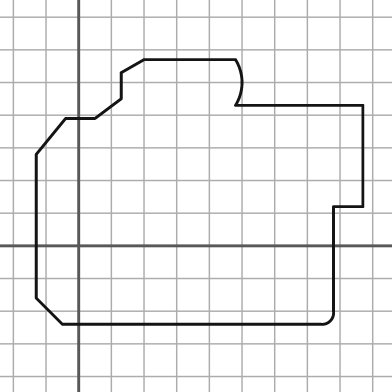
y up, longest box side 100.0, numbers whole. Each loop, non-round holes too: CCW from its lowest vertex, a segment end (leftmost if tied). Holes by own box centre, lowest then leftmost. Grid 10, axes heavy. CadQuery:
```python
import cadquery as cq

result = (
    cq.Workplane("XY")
    .moveTo(-5.0, -24.0)
    .lineTo(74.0, -24.0)
    .threePointArc((77.0, -23.0), (78.0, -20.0))
    .lineTo(78.0, 12.0)
    .lineTo(87.0, 12.0)
    .lineTo(87.0, 43.0)
    .lineTo(48.0, 43.0)
    .threePointArc((50.0, 50.0), (48.0, 57.0))
    .lineTo(20.0, 57.0)
    .lineTo(13.0, 53.0)
    .lineTo(13.0, 45.0)
    .lineTo(5.0, 39.0)
    .lineTo(-4.0, 39.0)
    .lineTo(-13.0, 28.0)
    .lineTo(-13.0, -16.0)
    .close()
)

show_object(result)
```